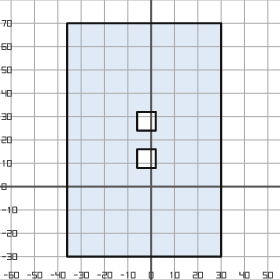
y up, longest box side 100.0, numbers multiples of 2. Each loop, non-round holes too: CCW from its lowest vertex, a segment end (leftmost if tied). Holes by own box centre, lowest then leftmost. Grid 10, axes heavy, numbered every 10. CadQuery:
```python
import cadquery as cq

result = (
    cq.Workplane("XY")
    .moveTo(-36.0, -30.0)
    .lineTo(30.0, -30.0)
    .lineTo(30.0, 70.0)
    .lineTo(-36.0, 70.0)
    .close()
    .moveTo(-6.0, 8.0)
    .lineTo(2.0, 8.0)
    .lineTo(2.0, 16.0)
    .lineTo(-6.0, 16.0)
    .close()
    .moveTo(-6.0, 24.0)
    .lineTo(2.0, 24.0)
    .lineTo(2.0, 32.0)
    .lineTo(-6.0, 32.0)
    .close()
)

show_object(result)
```